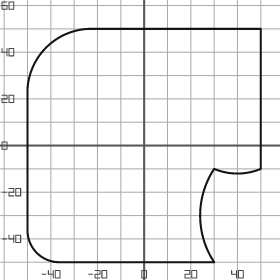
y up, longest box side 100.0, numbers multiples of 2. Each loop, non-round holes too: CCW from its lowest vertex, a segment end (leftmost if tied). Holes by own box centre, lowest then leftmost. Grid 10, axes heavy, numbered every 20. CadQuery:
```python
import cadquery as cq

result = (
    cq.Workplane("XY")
    .moveTo(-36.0, -50.0)
    .lineTo(30.0, -50.0)
    .threePointArc((24.0, -30.0), (30.0, -10.0))
    .threePointArc((40.0, -12.0), (50.0, -10.0))
    .lineTo(50.0, 50.0)
    .lineTo(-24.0, 50.0)
    .threePointArc((-42.0, 42.0), (-50.0, 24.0))
    .lineTo(-50.0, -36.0)
    .threePointArc((-46.0, -46.0), (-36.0, -50.0))
    .close()
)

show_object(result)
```